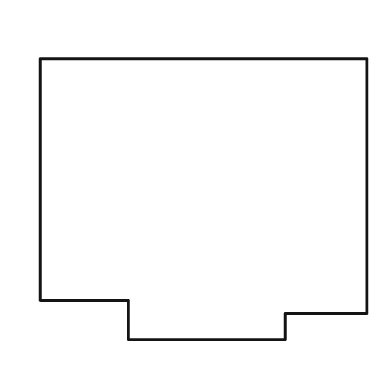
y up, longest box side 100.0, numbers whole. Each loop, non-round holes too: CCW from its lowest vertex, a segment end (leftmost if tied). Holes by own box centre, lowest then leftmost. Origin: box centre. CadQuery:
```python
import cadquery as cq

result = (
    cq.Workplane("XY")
    .moveTo(-23.0, -43.0)
    .lineTo(25.0, -43.0)
    .lineTo(25.0, -35.0)
    .lineTo(50.0, -35.0)
    .lineTo(50.0, 43.0)
    .lineTo(-50.0, 43.0)
    .lineTo(-50.0, -31.0)
    .lineTo(-23.0, -31.0)
    .close()
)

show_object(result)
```